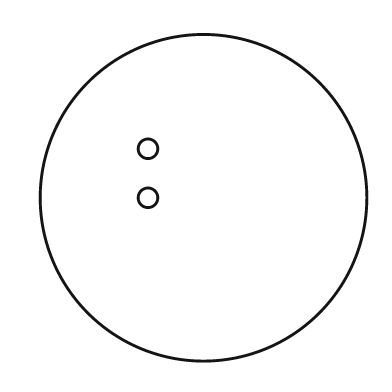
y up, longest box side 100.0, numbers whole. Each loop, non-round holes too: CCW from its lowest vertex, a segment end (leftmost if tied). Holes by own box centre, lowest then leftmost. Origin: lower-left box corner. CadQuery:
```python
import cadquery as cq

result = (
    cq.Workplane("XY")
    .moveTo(50.0, 50.0)
    .circle(50.0)
    .moveTo(33.0, 50.0)
    .circle(3.0)
    .moveTo(33.0, 65.0)
    .circle(3.0)
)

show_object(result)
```